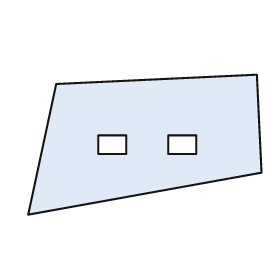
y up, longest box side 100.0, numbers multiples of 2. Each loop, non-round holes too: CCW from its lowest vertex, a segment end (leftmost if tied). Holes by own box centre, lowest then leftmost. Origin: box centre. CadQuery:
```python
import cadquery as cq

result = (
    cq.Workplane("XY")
    .moveTo(-50.0, -30.0)
    .lineTo(50.0, -12.0)
    .lineTo(48.0, 30.0)
    .lineTo(-38.0, 26.0)
    .close()
    .moveTo(-20.0, -4.0)
    .lineTo(-8.0, -4.0)
    .lineTo(-8.0, 4.0)
    .lineTo(-20.0, 4.0)
    .close()
    .moveTo(10.0, -4.0)
    .lineTo(22.0, -4.0)
    .lineTo(22.0, 4.0)
    .lineTo(10.0, 4.0)
    .close()
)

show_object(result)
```